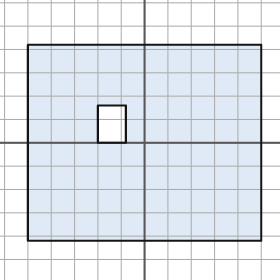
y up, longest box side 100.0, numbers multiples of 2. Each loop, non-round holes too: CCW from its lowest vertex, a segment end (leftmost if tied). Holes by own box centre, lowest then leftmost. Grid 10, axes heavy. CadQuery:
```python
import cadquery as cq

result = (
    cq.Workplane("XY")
    .moveTo(-50.0, -42.0)
    .lineTo(50.0, -42.0)
    .lineTo(50.0, 42.0)
    .lineTo(-50.0, 42.0)
    .close()
    .moveTo(-20.0, 0.0)
    .lineTo(-8.0, 0.0)
    .lineTo(-8.0, 16.0)
    .lineTo(-20.0, 16.0)
    .close()
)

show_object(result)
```